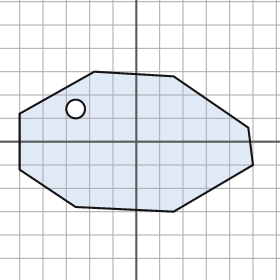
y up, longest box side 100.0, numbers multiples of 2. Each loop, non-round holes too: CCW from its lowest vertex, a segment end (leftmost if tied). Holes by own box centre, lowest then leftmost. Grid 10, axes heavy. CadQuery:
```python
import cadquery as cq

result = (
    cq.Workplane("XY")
    .moveTo(16.0, -30.0)
    .lineTo(50.0, -10.0)
    .lineTo(48.0, 6.0)
    .lineTo(16.0, 28.0)
    .lineTo(-18.0, 30.0)
    .lineTo(-50.0, 12.0)
    .lineTo(-50.0, -12.0)
    .lineTo(-26.0, -28.0)
    .close()
    .moveTo(-26.0, 14.0)
    .circle(4.0)
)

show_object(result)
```